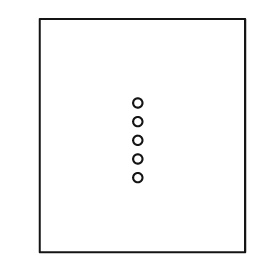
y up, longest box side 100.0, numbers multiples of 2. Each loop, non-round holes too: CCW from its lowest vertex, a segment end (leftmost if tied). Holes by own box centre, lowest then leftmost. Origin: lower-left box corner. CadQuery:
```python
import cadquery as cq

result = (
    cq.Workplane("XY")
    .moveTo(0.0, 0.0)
    .lineTo(88.0, 0.0)
    .lineTo(88.0, 100.0)
    .lineTo(0.0, 100.0)
    .close()
    .moveTo(42.0, 32.0)
    .circle(2.0)
    .moveTo(42.0, 40.0)
    .circle(2.0)
    .moveTo(42.0, 48.0)
    .circle(2.0)
    .moveTo(42.0, 56.0)
    .circle(2.0)
    .moveTo(42.0, 64.0)
    .circle(2.0)
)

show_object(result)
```